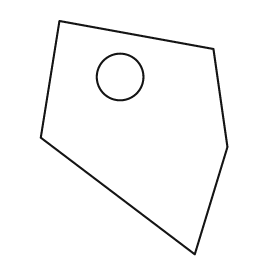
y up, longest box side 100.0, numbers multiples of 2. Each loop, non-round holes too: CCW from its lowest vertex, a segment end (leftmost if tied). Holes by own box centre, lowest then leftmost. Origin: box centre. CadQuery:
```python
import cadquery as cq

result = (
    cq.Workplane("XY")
    .moveTo(26.0, -50.0)
    .lineTo(40.0, -4.0)
    .lineTo(34.0, 38.0)
    .lineTo(-32.0, 50.0)
    .lineTo(-40.0, 0.0)
    .close()
    .moveTo(-6.0, 26.0)
    .circle(10.0)
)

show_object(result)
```